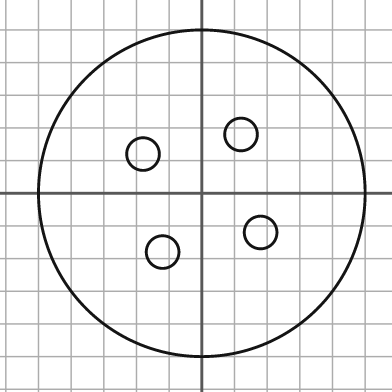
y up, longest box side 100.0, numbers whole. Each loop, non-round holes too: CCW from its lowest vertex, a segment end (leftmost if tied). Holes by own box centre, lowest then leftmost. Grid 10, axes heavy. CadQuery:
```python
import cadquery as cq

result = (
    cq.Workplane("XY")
    .moveTo(0.0, 0.0)
    .circle(50.0)
    .moveTo(-12.0, -18.0)
    .circle(5.0)
    .moveTo(18.0, -12.0)
    .circle(5.0)
    .moveTo(-18.0, 12.0)
    .circle(5.0)
    .moveTo(12.0, 18.0)
    .circle(5.0)
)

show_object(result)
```